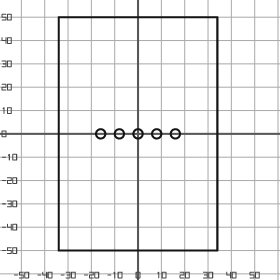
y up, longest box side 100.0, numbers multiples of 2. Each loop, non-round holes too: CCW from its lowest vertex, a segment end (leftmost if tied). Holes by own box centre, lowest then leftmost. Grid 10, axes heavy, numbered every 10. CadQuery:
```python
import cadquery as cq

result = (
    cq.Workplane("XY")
    .moveTo(-34.0, -50.0)
    .lineTo(34.0, -50.0)
    .lineTo(34.0, 50.0)
    .lineTo(-34.0, 50.0)
    .close()
    .moveTo(-16.0, 0.0)
    .circle(2.0)
    .moveTo(-8.0, 0.0)
    .circle(2.0)
    .moveTo(0.0, 0.0)
    .circle(2.0)
    .moveTo(8.0, 0.0)
    .circle(2.0)
    .moveTo(16.0, 0.0)
    .circle(2.0)
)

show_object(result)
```